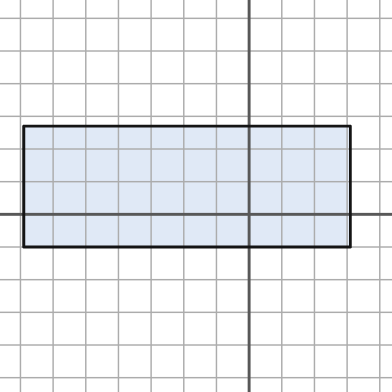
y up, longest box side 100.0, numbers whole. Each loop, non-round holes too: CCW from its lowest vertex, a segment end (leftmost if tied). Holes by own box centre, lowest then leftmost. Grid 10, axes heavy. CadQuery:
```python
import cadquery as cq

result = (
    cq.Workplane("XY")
    .moveTo(-69.0, -10.0)
    .lineTo(31.0, -10.0)
    .lineTo(31.0, 27.0)
    .lineTo(-69.0, 27.0)
    .close()
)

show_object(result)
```